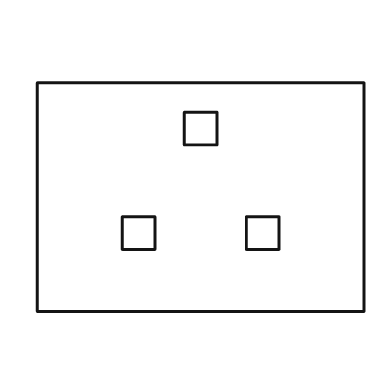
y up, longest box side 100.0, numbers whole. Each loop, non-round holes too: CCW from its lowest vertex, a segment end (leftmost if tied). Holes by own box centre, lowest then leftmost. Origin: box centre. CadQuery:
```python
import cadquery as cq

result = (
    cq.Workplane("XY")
    .moveTo(-50.0, -35.0)
    .lineTo(50.0, -35.0)
    .lineTo(50.0, 35.0)
    .lineTo(-50.0, 35.0)
    .close()
    .moveTo(-24.0, -16.0)
    .lineTo(-14.0, -16.0)
    .lineTo(-14.0, -6.0)
    .lineTo(-24.0, -6.0)
    .close()
    .moveTo(14.0, -16.0)
    .lineTo(24.0, -16.0)
    .lineTo(24.0, -6.0)
    .lineTo(14.0, -6.0)
    .close()
    .moveTo(-5.0, 16.0)
    .lineTo(5.0, 16.0)
    .lineTo(5.0, 26.0)
    .lineTo(-5.0, 26.0)
    .close()
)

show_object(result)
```